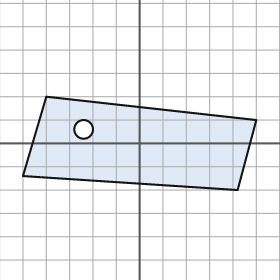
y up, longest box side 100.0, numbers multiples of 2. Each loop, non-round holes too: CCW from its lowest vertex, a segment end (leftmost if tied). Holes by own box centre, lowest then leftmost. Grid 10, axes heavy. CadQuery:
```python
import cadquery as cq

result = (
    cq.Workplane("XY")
    .moveTo(42.0, -20.0)
    .lineTo(50.0, 10.0)
    .lineTo(-40.0, 20.0)
    .lineTo(-50.0, -14.0)
    .close()
    .moveTo(-24.0, 6.0)
    .circle(4.0)
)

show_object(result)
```